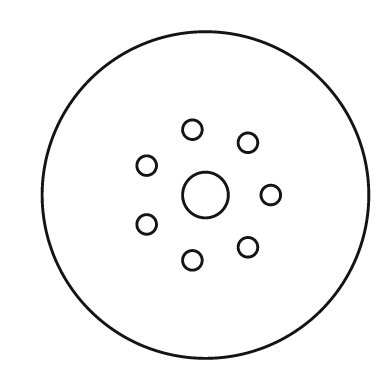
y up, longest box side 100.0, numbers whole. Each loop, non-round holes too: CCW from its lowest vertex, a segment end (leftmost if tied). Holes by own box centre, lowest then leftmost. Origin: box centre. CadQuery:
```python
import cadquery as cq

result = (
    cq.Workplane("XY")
    .moveTo(0.0, 0.0)
    .circle(50.0)
    .moveTo(-4.0, -20.0)
    .circle(3.0)
    .moveTo(13.0, -16.0)
    .circle(3.0)
    .moveTo(-18.0, -9.0)
    .circle(3.0)
    .moveTo(0.0, 0.0)
    .circle(7.0)
    .moveTo(20.0, 0.0)
    .circle(3.0)
    .moveTo(-18.0, 9.0)
    .circle(3.0)
    .moveTo(13.0, 16.0)
    .circle(3.0)
    .moveTo(-4.0, 20.0)
    .circle(3.0)
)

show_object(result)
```